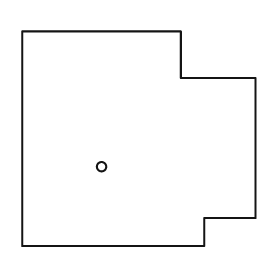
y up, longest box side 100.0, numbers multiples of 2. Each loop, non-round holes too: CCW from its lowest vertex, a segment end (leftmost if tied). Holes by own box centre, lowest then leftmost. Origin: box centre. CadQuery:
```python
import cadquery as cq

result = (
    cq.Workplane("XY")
    .moveTo(-50.0, -46.0)
    .lineTo(28.0, -46.0)
    .lineTo(28.0, -34.0)
    .lineTo(50.0, -34.0)
    .lineTo(50.0, 26.0)
    .lineTo(18.0, 26.0)
    .lineTo(18.0, 46.0)
    .lineTo(-50.0, 46.0)
    .close()
    .moveTo(-16.0, -12.0)
    .circle(2.0)
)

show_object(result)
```